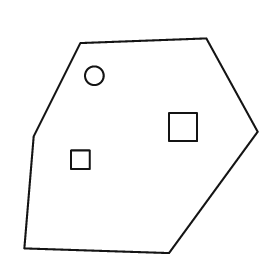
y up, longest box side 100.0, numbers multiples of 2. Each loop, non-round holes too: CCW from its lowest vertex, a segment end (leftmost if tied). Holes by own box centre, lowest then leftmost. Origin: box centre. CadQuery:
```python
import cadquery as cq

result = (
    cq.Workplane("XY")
    .moveTo(12.0, -46.0)
    .lineTo(50.0, 6.0)
    .lineTo(28.0, 46.0)
    .lineTo(-26.0, 44.0)
    .lineTo(-46.0, 4.0)
    .lineTo(-50.0, -44.0)
    .close()
    .moveTo(-30.0, -10.0)
    .lineTo(-22.0, -10.0)
    .lineTo(-22.0, -2.0)
    .lineTo(-30.0, -2.0)
    .close()
    .moveTo(12.0, 2.0)
    .lineTo(24.0, 2.0)
    .lineTo(24.0, 14.0)
    .lineTo(12.0, 14.0)
    .close()
    .moveTo(-20.0, 30.0)
    .circle(4.0)
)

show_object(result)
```